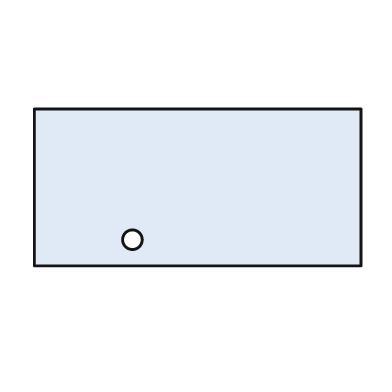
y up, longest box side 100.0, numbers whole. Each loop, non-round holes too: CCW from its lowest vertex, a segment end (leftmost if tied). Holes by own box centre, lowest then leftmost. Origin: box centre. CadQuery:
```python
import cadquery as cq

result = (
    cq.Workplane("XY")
    .moveTo(-50.0, -24.0)
    .lineTo(50.0, -24.0)
    .lineTo(50.0, 24.0)
    .lineTo(-50.0, 24.0)
    .close()
    .moveTo(-20.0, -16.0)
    .circle(3.0)
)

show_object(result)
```